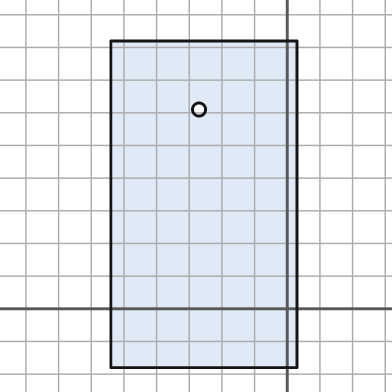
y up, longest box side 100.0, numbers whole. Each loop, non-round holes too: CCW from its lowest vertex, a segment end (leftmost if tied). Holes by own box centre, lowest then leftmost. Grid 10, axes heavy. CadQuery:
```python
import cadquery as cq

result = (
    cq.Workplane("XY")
    .moveTo(-54.0, -18.0)
    .lineTo(3.0, -18.0)
    .lineTo(3.0, 82.0)
    .lineTo(-54.0, 82.0)
    .close()
    .moveTo(-27.0, 61.0)
    .circle(2.0)
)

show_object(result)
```